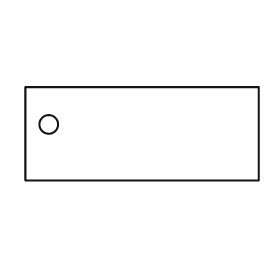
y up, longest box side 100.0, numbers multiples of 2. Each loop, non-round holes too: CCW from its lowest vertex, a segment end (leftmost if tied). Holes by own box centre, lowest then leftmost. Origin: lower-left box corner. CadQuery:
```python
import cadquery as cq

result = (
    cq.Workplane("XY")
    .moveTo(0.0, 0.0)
    .lineTo(100.0, 0.0)
    .lineTo(100.0, 40.0)
    .lineTo(0.0, 40.0)
    .close()
    .moveTo(10.0, 24.0)
    .circle(4.0)
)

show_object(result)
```